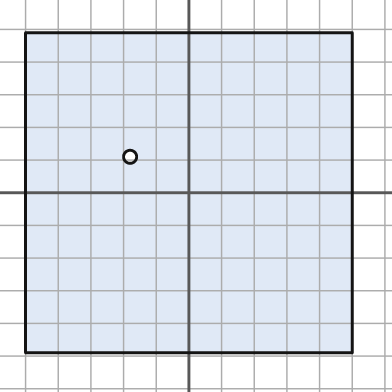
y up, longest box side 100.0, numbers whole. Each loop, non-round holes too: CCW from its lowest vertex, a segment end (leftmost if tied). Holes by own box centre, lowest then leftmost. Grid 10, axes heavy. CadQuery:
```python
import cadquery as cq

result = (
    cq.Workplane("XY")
    .moveTo(-50.0, -49.0)
    .lineTo(50.0, -49.0)
    .lineTo(50.0, 49.0)
    .lineTo(-50.0, 49.0)
    .close()
    .moveTo(-18.0, 11.0)
    .circle(2.0)
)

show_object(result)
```